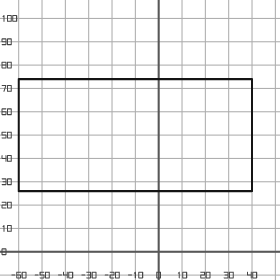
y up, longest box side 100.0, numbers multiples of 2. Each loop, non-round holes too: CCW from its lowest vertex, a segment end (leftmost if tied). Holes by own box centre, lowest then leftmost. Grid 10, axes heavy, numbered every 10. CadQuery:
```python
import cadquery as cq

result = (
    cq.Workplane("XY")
    .moveTo(-60.0, 26.0)
    .lineTo(40.0, 26.0)
    .lineTo(40.0, 74.0)
    .lineTo(-60.0, 74.0)
    .close()
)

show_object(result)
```